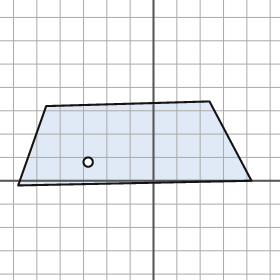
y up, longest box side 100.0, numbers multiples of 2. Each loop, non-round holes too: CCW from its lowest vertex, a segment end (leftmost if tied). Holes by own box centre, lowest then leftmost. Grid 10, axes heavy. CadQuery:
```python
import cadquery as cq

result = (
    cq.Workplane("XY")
    .moveTo(-58.0, -2.0)
    .lineTo(42.0, 0.0)
    .lineTo(24.0, 34.0)
    .lineTo(-46.0, 32.0)
    .close()
    .moveTo(-28.0, 8.0)
    .circle(2.0)
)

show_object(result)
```